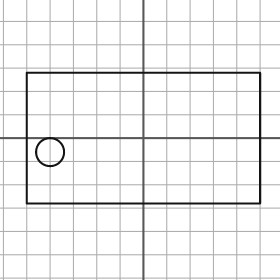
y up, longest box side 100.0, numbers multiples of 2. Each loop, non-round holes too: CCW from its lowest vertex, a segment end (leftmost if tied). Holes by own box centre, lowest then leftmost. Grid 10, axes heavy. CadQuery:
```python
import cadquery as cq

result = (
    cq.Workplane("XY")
    .moveTo(-50.0, -28.0)
    .lineTo(50.0, -28.0)
    .lineTo(50.0, 28.0)
    .lineTo(-50.0, 28.0)
    .close()
    .moveTo(-40.0, -6.0)
    .circle(6.0)
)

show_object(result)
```